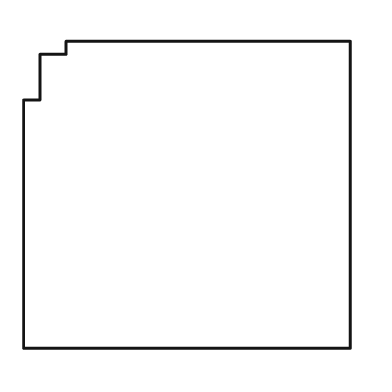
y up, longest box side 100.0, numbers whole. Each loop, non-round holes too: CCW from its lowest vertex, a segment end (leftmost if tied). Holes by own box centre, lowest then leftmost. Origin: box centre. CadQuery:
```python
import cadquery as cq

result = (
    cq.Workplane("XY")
    .moveTo(-50.0, -47.0)
    .lineTo(50.0, -47.0)
    .lineTo(50.0, 47.0)
    .lineTo(-37.0, 47.0)
    .lineTo(-37.0, 43.0)
    .lineTo(-45.0, 43.0)
    .lineTo(-45.0, 29.0)
    .lineTo(-50.0, 29.0)
    .close()
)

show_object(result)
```